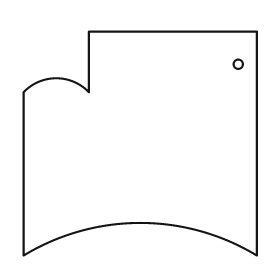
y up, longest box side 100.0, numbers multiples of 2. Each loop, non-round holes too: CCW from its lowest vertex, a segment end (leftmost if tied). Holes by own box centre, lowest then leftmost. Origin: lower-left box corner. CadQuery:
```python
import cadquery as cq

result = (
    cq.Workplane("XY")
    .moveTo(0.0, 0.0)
    .threePointArc((50.0, 14.0), (100.0, 0.0))
    .lineTo(100.0, 96.0)
    .lineTo(28.0, 96.0)
    .lineTo(28.0, 70.0)
    .threePointArc((14.0, 76.0), (0.0, 70.0))
    .close()
    .moveTo(92.0, 82.0)
    .circle(2.0)
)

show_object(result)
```